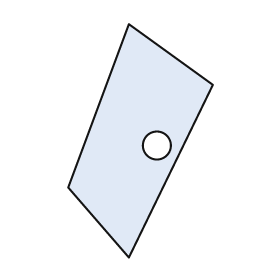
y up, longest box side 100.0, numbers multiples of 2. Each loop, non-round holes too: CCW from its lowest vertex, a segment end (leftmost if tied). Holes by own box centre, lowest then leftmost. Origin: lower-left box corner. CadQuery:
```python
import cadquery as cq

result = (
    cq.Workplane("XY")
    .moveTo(26.0, 0.0)
    .lineTo(62.0, 74.0)
    .lineTo(26.0, 100.0)
    .lineTo(0.0, 30.0)
    .close()
    .moveTo(38.0, 48.0)
    .circle(6.0)
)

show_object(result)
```